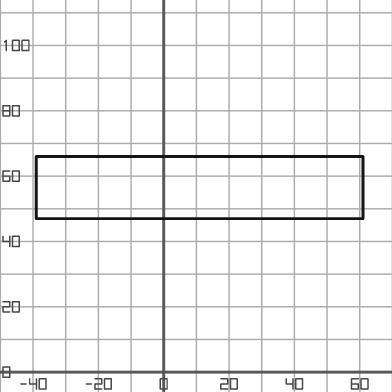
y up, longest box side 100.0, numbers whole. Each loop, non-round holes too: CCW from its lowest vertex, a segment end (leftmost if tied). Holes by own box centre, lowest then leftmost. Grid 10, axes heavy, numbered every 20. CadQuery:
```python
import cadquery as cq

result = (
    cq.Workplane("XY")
    .moveTo(-39.0, 47.0)
    .lineTo(61.0, 47.0)
    .lineTo(61.0, 66.0)
    .lineTo(-39.0, 66.0)
    .close()
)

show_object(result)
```